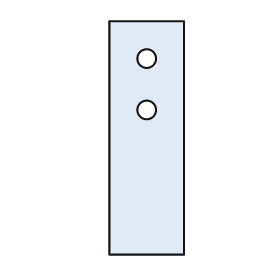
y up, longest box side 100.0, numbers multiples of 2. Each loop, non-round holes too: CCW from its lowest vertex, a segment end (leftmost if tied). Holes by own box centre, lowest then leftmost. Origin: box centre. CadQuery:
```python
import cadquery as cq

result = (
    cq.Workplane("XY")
    .moveTo(-16.0, -50.0)
    .lineTo(16.0, -50.0)
    .lineTo(16.0, 50.0)
    .lineTo(-16.0, 50.0)
    .close()
    .moveTo(0.0, 12.0)
    .circle(4.0)
    .moveTo(0.0, 34.0)
    .circle(4.0)
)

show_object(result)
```